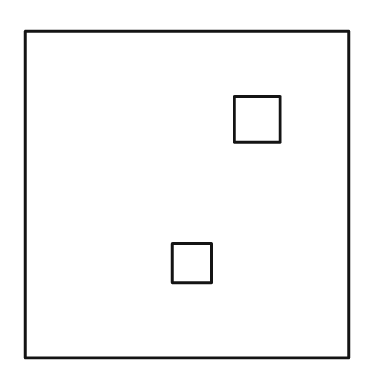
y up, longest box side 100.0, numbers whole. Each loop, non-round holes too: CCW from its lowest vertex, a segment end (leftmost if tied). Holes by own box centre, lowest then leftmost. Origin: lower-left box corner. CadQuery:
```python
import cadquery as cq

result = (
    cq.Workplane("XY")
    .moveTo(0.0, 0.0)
    .lineTo(99.0, 0.0)
    .lineTo(99.0, 100.0)
    .lineTo(0.0, 100.0)
    .close()
    .moveTo(45.0, 23.0)
    .lineTo(57.0, 23.0)
    .lineTo(57.0, 35.0)
    .lineTo(45.0, 35.0)
    .close()
    .moveTo(64.0, 66.0)
    .lineTo(78.0, 66.0)
    .lineTo(78.0, 80.0)
    .lineTo(64.0, 80.0)
    .close()
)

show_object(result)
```